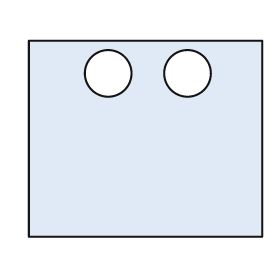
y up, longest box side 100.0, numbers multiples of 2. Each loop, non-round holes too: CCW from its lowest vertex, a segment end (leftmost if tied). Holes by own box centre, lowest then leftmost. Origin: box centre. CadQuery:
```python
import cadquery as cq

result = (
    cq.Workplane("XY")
    .moveTo(-50.0, -42.0)
    .lineTo(50.0, -42.0)
    .lineTo(50.0, 42.0)
    .lineTo(-50.0, 42.0)
    .close()
    .moveTo(-16.0, 28.0)
    .circle(10.0)
    .moveTo(18.0, 28.0)
    .circle(10.0)
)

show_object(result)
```